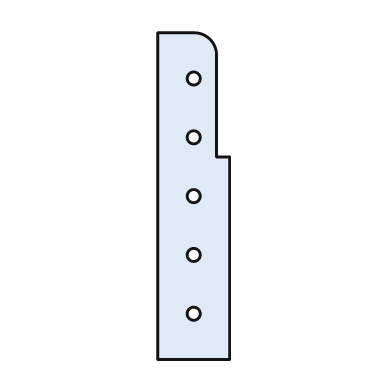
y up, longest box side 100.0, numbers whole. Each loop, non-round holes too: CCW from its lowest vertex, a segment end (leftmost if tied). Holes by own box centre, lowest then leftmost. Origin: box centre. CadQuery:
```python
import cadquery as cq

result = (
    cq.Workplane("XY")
    .moveTo(-11.0, -50.0)
    .lineTo(11.0, -50.0)
    .lineTo(11.0, 12.0)
    .lineTo(7.0, 12.0)
    .lineTo(7.0, 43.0)
    .threePointArc((5.0, 48.0), (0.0, 50.0))
    .lineTo(-11.0, 50.0)
    .close()
    .moveTo(0.0, -36.0)
    .circle(2.0)
    .moveTo(0.0, -18.0)
    .circle(2.0)
    .moveTo(0.0, 0.0)
    .circle(2.0)
    .moveTo(0.0, 18.0)
    .circle(2.0)
    .moveTo(0.0, 36.0)
    .circle(2.0)
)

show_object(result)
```